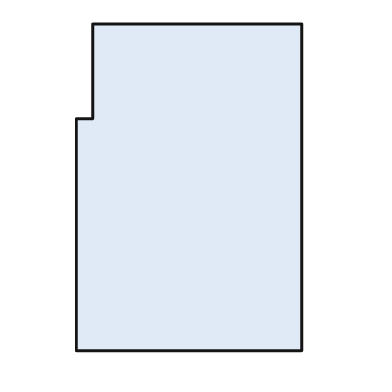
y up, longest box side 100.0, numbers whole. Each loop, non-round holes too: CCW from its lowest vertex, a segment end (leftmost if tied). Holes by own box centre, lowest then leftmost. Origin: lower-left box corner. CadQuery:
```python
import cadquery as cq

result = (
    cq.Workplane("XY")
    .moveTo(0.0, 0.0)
    .lineTo(69.0, 0.0)
    .lineTo(69.0, 100.0)
    .lineTo(5.0, 100.0)
    .lineTo(5.0, 71.0)
    .lineTo(0.0, 71.0)
    .close()
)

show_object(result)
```